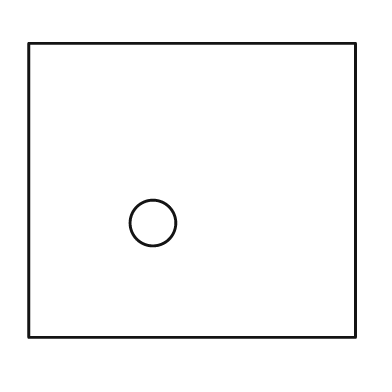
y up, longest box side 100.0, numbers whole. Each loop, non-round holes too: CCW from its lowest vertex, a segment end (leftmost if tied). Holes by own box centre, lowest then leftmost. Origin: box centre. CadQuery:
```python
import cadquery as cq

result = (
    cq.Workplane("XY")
    .moveTo(-50.0, -45.0)
    .lineTo(50.0, -45.0)
    .lineTo(50.0, 45.0)
    .lineTo(-50.0, 45.0)
    .close()
    .moveTo(-12.0, -10.0)
    .circle(7.0)
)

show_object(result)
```